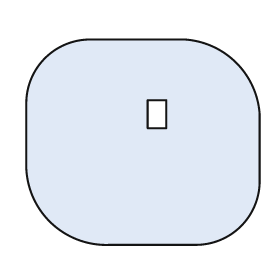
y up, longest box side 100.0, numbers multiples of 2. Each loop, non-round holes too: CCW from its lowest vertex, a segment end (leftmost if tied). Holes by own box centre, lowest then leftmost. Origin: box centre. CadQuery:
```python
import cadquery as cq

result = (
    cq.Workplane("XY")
    .moveTo(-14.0, -44.0)
    .lineTo(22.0, -44.0)
    .threePointArc((42.0, -36.0), (50.0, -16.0))
    .lineTo(50.0, 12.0)
    .threePointArc((40.0, 34.0), (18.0, 44.0))
    .lineTo(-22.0, 44.0)
    .threePointArc((-42.0, 36.0), (-50.0, 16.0))
    .lineTo(-50.0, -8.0)
    .threePointArc((-40.0, -34.0), (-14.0, -44.0))
    .close()
    .moveTo(2.0, 6.0)
    .lineTo(10.0, 6.0)
    .lineTo(10.0, 18.0)
    .lineTo(2.0, 18.0)
    .close()
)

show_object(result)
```